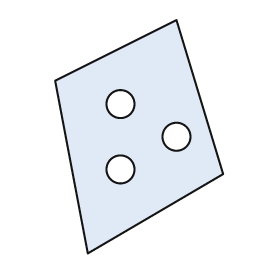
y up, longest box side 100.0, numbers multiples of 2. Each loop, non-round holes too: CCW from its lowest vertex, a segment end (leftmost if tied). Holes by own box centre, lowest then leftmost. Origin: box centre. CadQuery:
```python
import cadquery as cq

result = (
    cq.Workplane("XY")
    .moveTo(-22.0, -50.0)
    .lineTo(36.0, -16.0)
    .lineTo(16.0, 50.0)
    .lineTo(-36.0, 24.0)
    .close()
    .moveTo(-8.0, -14.0)
    .circle(6.0)
    .moveTo(16.0, 0.0)
    .circle(6.0)
    .moveTo(-8.0, 14.0)
    .circle(6.0)
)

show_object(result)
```